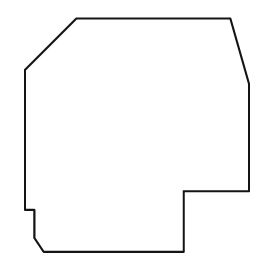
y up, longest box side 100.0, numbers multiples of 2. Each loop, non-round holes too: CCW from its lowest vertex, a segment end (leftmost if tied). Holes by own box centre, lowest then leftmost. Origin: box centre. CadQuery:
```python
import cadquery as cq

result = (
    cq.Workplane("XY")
    .moveTo(-40.0, -50.0)
    .lineTo(20.0, -50.0)
    .lineTo(20.0, -24.0)
    .lineTo(48.0, -24.0)
    .lineTo(48.0, 22.0)
    .lineTo(40.0, 50.0)
    .lineTo(-26.0, 50.0)
    .lineTo(-48.0, 28.0)
    .lineTo(-48.0, -32.0)
    .lineTo(-44.0, -32.0)
    .lineTo(-44.0, -44.0)
    .close()
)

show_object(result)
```